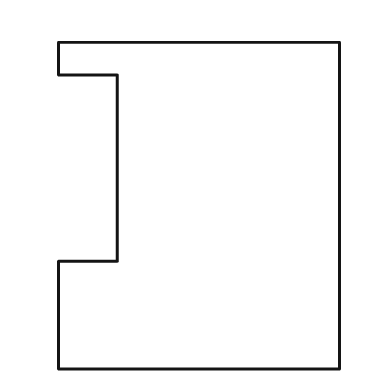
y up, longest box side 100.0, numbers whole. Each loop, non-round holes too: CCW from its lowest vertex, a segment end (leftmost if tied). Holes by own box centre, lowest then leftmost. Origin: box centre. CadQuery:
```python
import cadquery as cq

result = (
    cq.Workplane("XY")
    .moveTo(-43.0, -50.0)
    .lineTo(43.0, -50.0)
    .lineTo(43.0, 50.0)
    .lineTo(-43.0, 50.0)
    .lineTo(-43.0, 40.0)
    .lineTo(-25.0, 40.0)
    .lineTo(-25.0, -17.0)
    .lineTo(-43.0, -17.0)
    .close()
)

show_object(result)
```